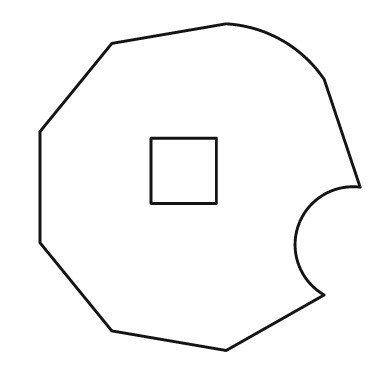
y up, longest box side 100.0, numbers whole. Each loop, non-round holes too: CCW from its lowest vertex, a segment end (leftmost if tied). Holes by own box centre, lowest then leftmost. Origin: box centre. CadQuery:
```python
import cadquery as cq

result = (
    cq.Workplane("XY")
    .moveTo(8.0, -50.0)
    .lineTo(38.0, -33.0)
    .threePointArc((30.0, -12.0), (49.0, 0.0))
    .lineTo(38.0, 33.0)
    .threePointArc((25.0, 45.0), (8.0, 50.0))
    .lineTo(-27.0, 44.0)
    .lineTo(-49.0, 17.0)
    .lineTo(-49.0, -17.0)
    .lineTo(-27.0, -44.0)
    .close()
    .moveTo(-15.0, -5.0)
    .lineTo(5.0, -5.0)
    .lineTo(5.0, 15.0)
    .lineTo(-15.0, 15.0)
    .close()
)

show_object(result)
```